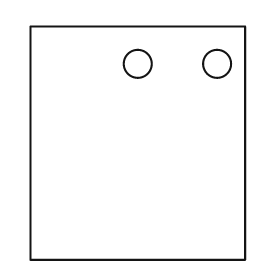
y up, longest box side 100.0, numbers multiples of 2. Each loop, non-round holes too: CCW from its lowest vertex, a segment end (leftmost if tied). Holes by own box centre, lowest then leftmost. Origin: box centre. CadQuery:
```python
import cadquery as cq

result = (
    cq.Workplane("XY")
    .moveTo(-46.0, -50.0)
    .lineTo(46.0, -50.0)
    .lineTo(46.0, 50.0)
    .lineTo(-46.0, 50.0)
    .close()
    .moveTo(0.0, 34.0)
    .circle(6.0)
    .moveTo(34.0, 34.0)
    .circle(6.0)
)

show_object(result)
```